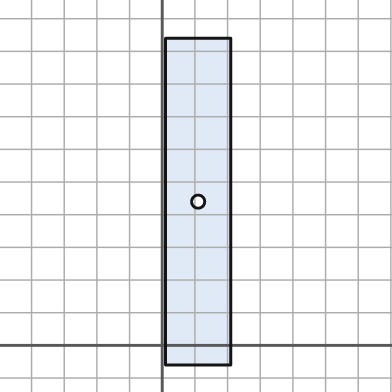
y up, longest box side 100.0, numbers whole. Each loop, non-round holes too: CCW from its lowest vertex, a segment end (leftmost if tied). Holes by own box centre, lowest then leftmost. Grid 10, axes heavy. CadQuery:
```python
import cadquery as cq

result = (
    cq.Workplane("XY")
    .moveTo(1.0, -6.0)
    .lineTo(21.0, -6.0)
    .lineTo(21.0, 94.0)
    .lineTo(1.0, 94.0)
    .close()
    .moveTo(11.0, 44.0)
    .circle(2.0)
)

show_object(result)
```